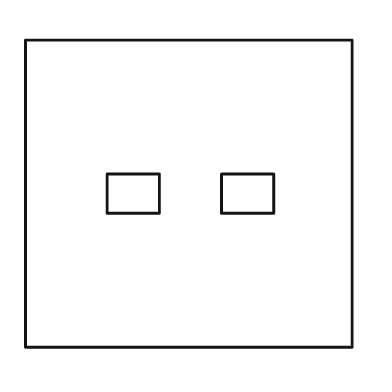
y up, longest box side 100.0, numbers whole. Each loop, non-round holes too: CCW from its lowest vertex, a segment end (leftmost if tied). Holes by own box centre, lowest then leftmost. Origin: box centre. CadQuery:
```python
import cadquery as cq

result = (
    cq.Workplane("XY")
    .moveTo(-50.0, -47.0)
    .lineTo(50.0, -47.0)
    .lineTo(50.0, 47.0)
    .lineTo(-50.0, 47.0)
    .close()
    .moveTo(-25.0, -6.0)
    .lineTo(-9.0, -6.0)
    .lineTo(-9.0, 6.0)
    .lineTo(-25.0, 6.0)
    .close()
    .moveTo(10.0, -6.0)
    .lineTo(26.0, -6.0)
    .lineTo(26.0, 6.0)
    .lineTo(10.0, 6.0)
    .close()
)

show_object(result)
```